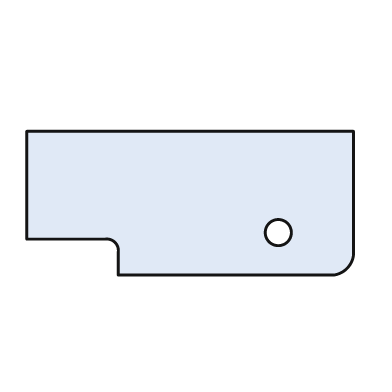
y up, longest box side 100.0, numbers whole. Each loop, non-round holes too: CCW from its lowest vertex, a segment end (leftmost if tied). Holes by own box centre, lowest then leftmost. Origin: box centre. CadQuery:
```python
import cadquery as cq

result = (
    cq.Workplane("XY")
    .moveTo(-22.0, -22.0)
    .lineTo(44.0, -22.0)
    .threePointArc((48.0, -20.0), (50.0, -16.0))
    .lineTo(50.0, 22.0)
    .lineTo(-50.0, 22.0)
    .lineTo(-50.0, -11.0)
    .lineTo(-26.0, -11.0)
    .threePointArc((-23.0, -12.0), (-22.0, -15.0))
    .close()
    .moveTo(27.0, -9.0)
    .circle(4.0)
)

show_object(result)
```